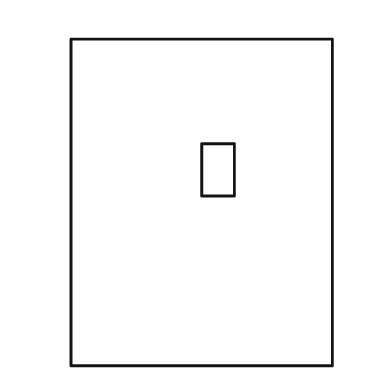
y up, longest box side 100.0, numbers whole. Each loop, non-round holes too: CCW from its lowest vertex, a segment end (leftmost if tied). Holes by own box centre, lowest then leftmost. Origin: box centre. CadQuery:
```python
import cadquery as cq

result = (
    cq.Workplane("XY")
    .moveTo(-40.0, -50.0)
    .lineTo(40.0, -50.0)
    .lineTo(40.0, 50.0)
    .lineTo(-40.0, 50.0)
    .close()
    .moveTo(0.0, 2.0)
    .lineTo(10.0, 2.0)
    .lineTo(10.0, 18.0)
    .lineTo(0.0, 18.0)
    .close()
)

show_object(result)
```